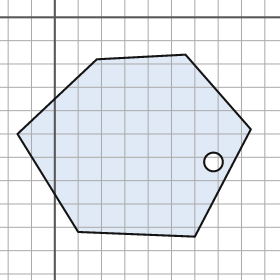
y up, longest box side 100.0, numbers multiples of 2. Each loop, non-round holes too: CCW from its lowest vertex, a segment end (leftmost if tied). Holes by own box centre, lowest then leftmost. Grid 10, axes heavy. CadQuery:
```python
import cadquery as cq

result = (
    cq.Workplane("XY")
    .moveTo(60.0, -94.0)
    .lineTo(84.0, -48.0)
    .lineTo(56.0, -16.0)
    .lineTo(18.0, -18.0)
    .lineTo(-16.0, -50.0)
    .lineTo(10.0, -92.0)
    .close()
    .moveTo(68.0, -62.0)
    .circle(4.0)
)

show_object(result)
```